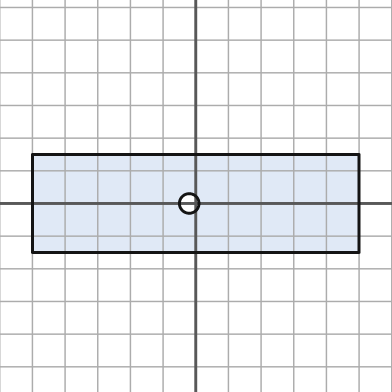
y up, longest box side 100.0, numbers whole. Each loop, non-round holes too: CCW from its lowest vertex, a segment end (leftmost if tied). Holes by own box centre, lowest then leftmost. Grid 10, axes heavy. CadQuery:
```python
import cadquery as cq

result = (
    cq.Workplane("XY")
    .moveTo(-50.0, -15.0)
    .lineTo(50.0, -15.0)
    .lineTo(50.0, 15.0)
    .lineTo(-50.0, 15.0)
    .close()
    .moveTo(-2.0, 0.0)
    .circle(3.0)
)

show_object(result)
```